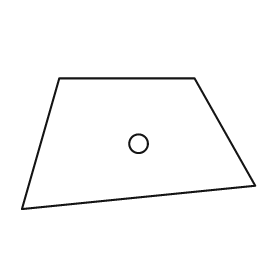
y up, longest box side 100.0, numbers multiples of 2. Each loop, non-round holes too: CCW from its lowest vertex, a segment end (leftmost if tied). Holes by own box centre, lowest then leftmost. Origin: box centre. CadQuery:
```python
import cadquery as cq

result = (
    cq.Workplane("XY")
    .moveTo(-50.0, -28.0)
    .lineTo(50.0, -18.0)
    .lineTo(24.0, 28.0)
    .lineTo(-34.0, 28.0)
    .close()
    .moveTo(0.0, 0.0)
    .circle(4.0)
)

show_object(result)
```